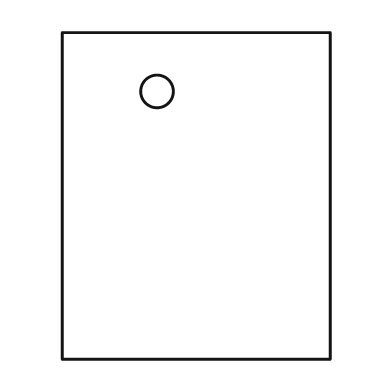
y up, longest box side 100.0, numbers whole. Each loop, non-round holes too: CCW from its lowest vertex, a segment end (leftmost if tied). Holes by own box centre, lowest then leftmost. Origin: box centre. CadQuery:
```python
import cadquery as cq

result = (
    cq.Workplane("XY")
    .moveTo(-41.0, -50.0)
    .lineTo(41.0, -50.0)
    .lineTo(41.0, 50.0)
    .lineTo(-41.0, 50.0)
    .close()
    .moveTo(-12.0, 32.0)
    .circle(5.0)
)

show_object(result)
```